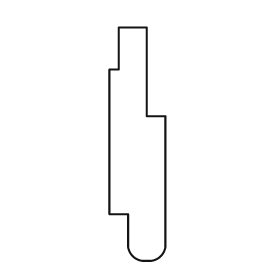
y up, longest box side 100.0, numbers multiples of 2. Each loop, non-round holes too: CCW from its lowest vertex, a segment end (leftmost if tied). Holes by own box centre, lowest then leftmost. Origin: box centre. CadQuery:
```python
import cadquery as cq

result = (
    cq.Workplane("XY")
    .moveTo(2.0, -50.0)
    .lineTo(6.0, -50.0)
    .threePointArc((10.0, -48.0), (12.0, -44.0))
    .lineTo(12.0, 12.0)
    .lineTo(4.0, 12.0)
    .lineTo(4.0, 50.0)
    .lineTo(-8.0, 50.0)
    .lineTo(-8.0, 32.0)
    .lineTo(-12.0, 32.0)
    .lineTo(-12.0, -30.0)
    .lineTo(-4.0, -30.0)
    .lineTo(-4.0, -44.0)
    .threePointArc((-2.0, -48.0), (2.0, -50.0))
    .close()
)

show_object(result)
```